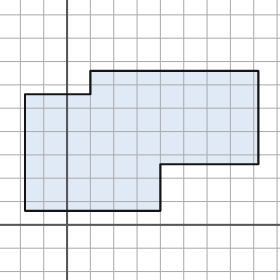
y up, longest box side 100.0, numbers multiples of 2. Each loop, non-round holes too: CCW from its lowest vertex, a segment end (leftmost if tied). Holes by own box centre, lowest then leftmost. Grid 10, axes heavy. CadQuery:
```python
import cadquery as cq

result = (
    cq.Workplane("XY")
    .moveTo(-18.0, 6.0)
    .lineTo(40.0, 6.0)
    .lineTo(40.0, 26.0)
    .lineTo(82.0, 26.0)
    .lineTo(82.0, 66.0)
    .lineTo(10.0, 66.0)
    .lineTo(10.0, 56.0)
    .lineTo(-18.0, 56.0)
    .close()
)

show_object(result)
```